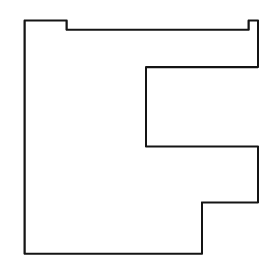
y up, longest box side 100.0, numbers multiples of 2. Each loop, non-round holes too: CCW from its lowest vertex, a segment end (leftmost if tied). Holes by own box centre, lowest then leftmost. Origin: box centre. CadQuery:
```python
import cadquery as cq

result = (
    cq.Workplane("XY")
    .moveTo(-50.0, -50.0)
    .lineTo(26.0, -50.0)
    .lineTo(26.0, -28.0)
    .lineTo(50.0, -28.0)
    .lineTo(50.0, -4.0)
    .lineTo(2.0, -4.0)
    .lineTo(2.0, 30.0)
    .lineTo(50.0, 30.0)
    .lineTo(50.0, 50.0)
    .lineTo(46.0, 50.0)
    .lineTo(46.0, 46.0)
    .lineTo(-32.0, 46.0)
    .lineTo(-32.0, 50.0)
    .lineTo(-50.0, 50.0)
    .close()
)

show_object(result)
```